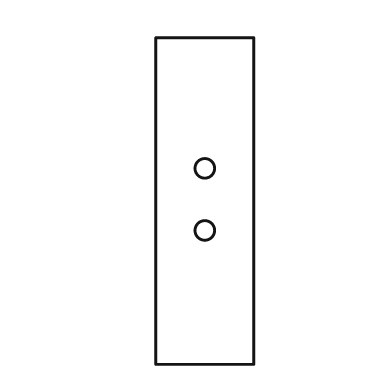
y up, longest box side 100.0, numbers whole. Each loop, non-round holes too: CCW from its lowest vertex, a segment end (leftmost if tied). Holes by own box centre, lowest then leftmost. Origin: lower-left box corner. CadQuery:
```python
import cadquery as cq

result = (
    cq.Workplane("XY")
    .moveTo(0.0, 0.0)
    .lineTo(30.0, 0.0)
    .lineTo(30.0, 100.0)
    .lineTo(0.0, 100.0)
    .close()
    .moveTo(15.0, 41.0)
    .circle(3.0)
    .moveTo(15.0, 60.0)
    .circle(3.0)
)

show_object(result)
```